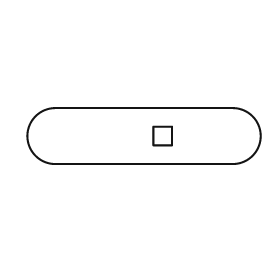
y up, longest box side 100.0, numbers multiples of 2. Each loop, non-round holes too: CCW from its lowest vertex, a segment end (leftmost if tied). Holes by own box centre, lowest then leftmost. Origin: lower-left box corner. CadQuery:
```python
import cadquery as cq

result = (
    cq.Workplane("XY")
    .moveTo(12.0, 0.0)
    .lineTo(88.0, 0.0)
    .threePointArc((100.0, 12.0), (88.0, 24.0))
    .lineTo(12.0, 24.0)
    .threePointArc((0.0, 12.0), (12.0, 0.0))
    .close()
    .moveTo(54.0, 8.0)
    .lineTo(62.0, 8.0)
    .lineTo(62.0, 16.0)
    .lineTo(54.0, 16.0)
    .close()
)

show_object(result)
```